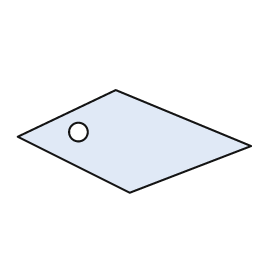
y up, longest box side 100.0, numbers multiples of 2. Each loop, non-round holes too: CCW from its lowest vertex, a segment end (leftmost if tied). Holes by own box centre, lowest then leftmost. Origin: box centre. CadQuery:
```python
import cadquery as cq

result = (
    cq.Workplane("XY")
    .moveTo(-2.0, -22.0)
    .lineTo(50.0, -2.0)
    .lineTo(-8.0, 22.0)
    .lineTo(-50.0, 2.0)
    .close()
    .moveTo(-24.0, 4.0)
    .circle(4.0)
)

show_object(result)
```